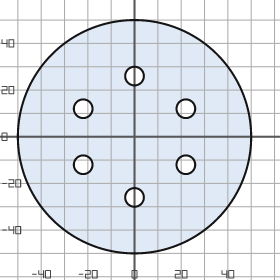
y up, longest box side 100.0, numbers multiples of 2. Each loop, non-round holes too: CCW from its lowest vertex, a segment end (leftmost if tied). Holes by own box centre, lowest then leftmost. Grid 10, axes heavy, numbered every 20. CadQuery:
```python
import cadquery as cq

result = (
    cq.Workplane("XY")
    .moveTo(0.0, 0.0)
    .circle(50.0)
    .moveTo(0.0, -26.0)
    .circle(4.0)
    .moveTo(-22.0, -12.0)
    .circle(4.0)
    .moveTo(22.0, -12.0)
    .circle(4.0)
    .moveTo(-22.0, 12.0)
    .circle(4.0)
    .moveTo(22.0, 12.0)
    .circle(4.0)
    .moveTo(0.0, 26.0)
    .circle(4.0)
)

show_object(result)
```